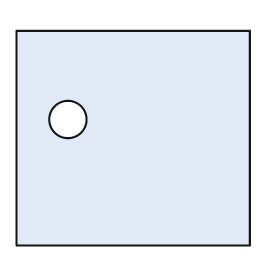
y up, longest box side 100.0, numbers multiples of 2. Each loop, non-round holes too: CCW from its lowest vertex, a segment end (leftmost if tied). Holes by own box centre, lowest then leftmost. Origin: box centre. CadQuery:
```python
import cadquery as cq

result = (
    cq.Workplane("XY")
    .moveTo(-50.0, -46.0)
    .lineTo(50.0, -46.0)
    .lineTo(50.0, 46.0)
    .lineTo(-50.0, 46.0)
    .close()
    .moveTo(-28.0, 8.0)
    .circle(8.0)
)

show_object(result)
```